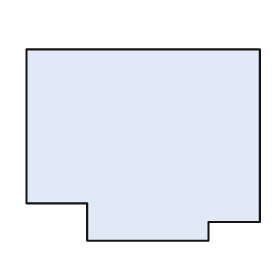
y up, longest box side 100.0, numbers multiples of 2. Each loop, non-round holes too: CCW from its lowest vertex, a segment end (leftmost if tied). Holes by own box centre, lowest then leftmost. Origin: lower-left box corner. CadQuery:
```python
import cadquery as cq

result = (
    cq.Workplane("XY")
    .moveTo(26.0, 0.0)
    .lineTo(78.0, 0.0)
    .lineTo(78.0, 8.0)
    .lineTo(100.0, 8.0)
    .lineTo(100.0, 82.0)
    .lineTo(0.0, 82.0)
    .lineTo(0.0, 16.0)
    .lineTo(26.0, 16.0)
    .close()
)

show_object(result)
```